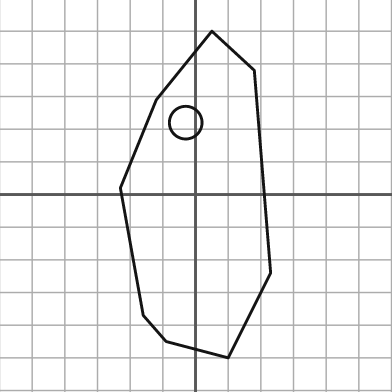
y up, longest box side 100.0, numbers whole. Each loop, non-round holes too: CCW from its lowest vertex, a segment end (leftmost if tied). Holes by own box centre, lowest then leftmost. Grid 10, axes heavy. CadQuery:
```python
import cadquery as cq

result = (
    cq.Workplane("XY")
    .moveTo(10.0, -50.0)
    .lineTo(23.0, -24.0)
    .lineTo(18.0, 38.0)
    .lineTo(5.0, 50.0)
    .lineTo(-12.0, 29.0)
    .lineTo(-23.0, 2.0)
    .lineTo(-16.0, -37.0)
    .lineTo(-9.0, -45.0)
    .close()
    .moveTo(-3.0, 22.0)
    .circle(5.0)
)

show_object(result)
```